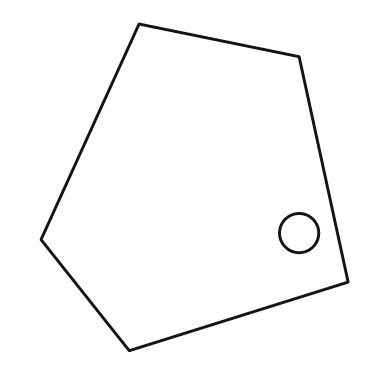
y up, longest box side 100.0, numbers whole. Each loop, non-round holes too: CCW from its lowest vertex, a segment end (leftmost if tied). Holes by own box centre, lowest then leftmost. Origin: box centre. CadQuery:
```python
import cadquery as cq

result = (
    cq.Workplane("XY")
    .moveTo(-20.0, -50.0)
    .lineTo(47.0, -29.0)
    .lineTo(32.0, 40.0)
    .lineTo(-17.0, 50.0)
    .lineTo(-47.0, -16.0)
    .close()
    .moveTo(32.0, -14.0)
    .circle(6.0)
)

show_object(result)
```